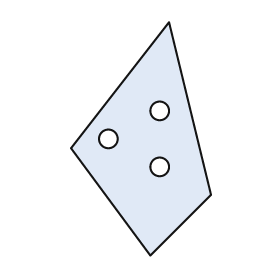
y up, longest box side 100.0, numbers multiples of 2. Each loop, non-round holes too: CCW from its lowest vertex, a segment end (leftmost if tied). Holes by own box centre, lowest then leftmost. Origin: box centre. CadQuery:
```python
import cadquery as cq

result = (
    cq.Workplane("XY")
    .moveTo(4.0, -50.0)
    .lineTo(30.0, -24.0)
    .lineTo(12.0, 50.0)
    .lineTo(-30.0, -4.0)
    .close()
    .moveTo(8.0, -12.0)
    .circle(4.0)
    .moveTo(-14.0, 0.0)
    .circle(4.0)
    .moveTo(8.0, 12.0)
    .circle(4.0)
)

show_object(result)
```